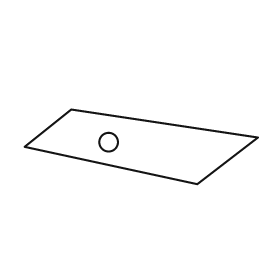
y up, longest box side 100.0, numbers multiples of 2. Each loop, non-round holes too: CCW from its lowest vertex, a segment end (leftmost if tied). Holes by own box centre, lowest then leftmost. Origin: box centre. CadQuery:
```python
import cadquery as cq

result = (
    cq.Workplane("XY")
    .moveTo(24.0, -16.0)
    .lineTo(50.0, 4.0)
    .lineTo(-30.0, 16.0)
    .lineTo(-50.0, 0.0)
    .close()
    .moveTo(-14.0, 2.0)
    .circle(4.0)
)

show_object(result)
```